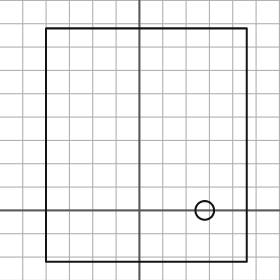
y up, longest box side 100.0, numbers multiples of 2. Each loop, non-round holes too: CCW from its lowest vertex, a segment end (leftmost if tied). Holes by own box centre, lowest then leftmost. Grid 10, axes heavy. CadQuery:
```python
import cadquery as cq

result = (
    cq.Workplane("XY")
    .moveTo(-40.0, -22.0)
    .lineTo(46.0, -22.0)
    .lineTo(46.0, 78.0)
    .lineTo(-40.0, 78.0)
    .close()
    .moveTo(28.0, 0.0)
    .circle(4.0)
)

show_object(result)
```